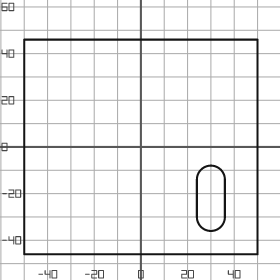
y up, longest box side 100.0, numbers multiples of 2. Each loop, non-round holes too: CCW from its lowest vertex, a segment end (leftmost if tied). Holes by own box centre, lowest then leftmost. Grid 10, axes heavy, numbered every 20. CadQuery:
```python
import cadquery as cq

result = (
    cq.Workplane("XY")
    .moveTo(-50.0, -46.0)
    .lineTo(50.0, -46.0)
    .lineTo(50.0, 46.0)
    .lineTo(-50.0, 46.0)
    .close()
    .moveTo(24.0, -30.0)
    .threePointArc((30.0, -36.0), (36.0, -30.0))
    .lineTo(36.0, -14.0)
    .threePointArc((30.0, -8.0), (24.0, -14.0))
    .close()
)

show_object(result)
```